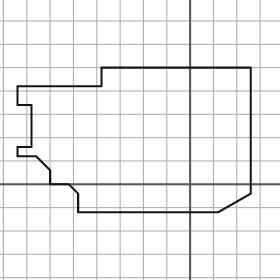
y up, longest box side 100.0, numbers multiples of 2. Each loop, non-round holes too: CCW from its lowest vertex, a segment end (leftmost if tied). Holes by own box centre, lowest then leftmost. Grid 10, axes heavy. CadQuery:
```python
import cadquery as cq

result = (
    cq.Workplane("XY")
    .moveTo(-48.0, -12.0)
    .lineTo(12.0, -12.0)
    .lineTo(26.0, -4.0)
    .lineTo(26.0, 50.0)
    .lineTo(-38.0, 50.0)
    .lineTo(-38.0, 42.0)
    .lineTo(-74.0, 42.0)
    .lineTo(-74.0, 34.0)
    .lineTo(-68.0, 34.0)
    .lineTo(-68.0, 16.0)
    .lineTo(-74.0, 16.0)
    .lineTo(-74.0, 12.0)
    .lineTo(-66.0, 12.0)
    .lineTo(-60.0, 6.0)
    .lineTo(-60.0, 0.0)
    .lineTo(-52.0, 0.0)
    .lineTo(-48.0, -4.0)
    .close()
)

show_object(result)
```